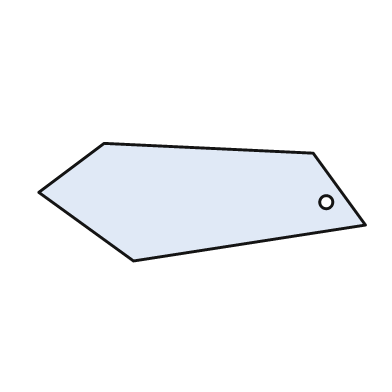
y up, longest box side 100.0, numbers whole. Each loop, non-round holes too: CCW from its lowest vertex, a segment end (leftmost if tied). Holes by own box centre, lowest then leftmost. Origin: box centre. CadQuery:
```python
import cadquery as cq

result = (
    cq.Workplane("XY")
    .moveTo(-21.0, -18.0)
    .lineTo(50.0, -7.0)
    .lineTo(34.0, 15.0)
    .lineTo(-30.0, 18.0)
    .lineTo(-50.0, 3.0)
    .close()
    .moveTo(38.0, 0.0)
    .circle(2.0)
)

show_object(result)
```